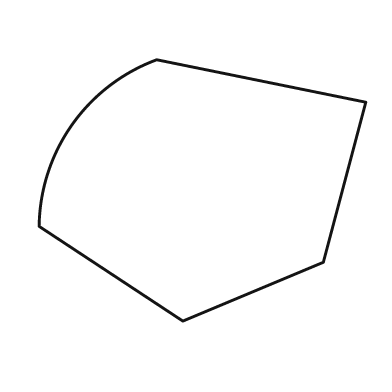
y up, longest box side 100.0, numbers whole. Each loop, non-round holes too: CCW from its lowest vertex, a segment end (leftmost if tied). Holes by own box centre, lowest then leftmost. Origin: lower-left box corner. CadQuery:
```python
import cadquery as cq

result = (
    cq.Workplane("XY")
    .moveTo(44.0, 0.0)
    .lineTo(87.0, 18.0)
    .lineTo(100.0, 67.0)
    .lineTo(36.0, 80.0)
    .threePointArc((10.0, 60.0), (0.0, 29.0))
    .close()
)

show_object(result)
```